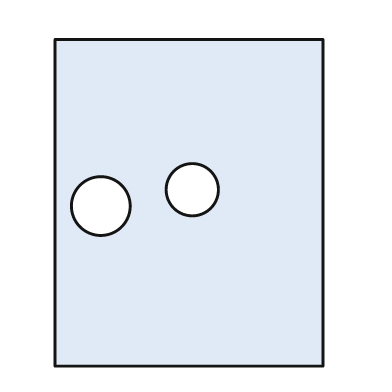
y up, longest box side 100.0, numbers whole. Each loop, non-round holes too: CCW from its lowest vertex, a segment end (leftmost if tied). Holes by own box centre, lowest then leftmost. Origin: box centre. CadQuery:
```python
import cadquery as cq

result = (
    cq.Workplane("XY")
    .moveTo(-41.0, -50.0)
    .lineTo(41.0, -50.0)
    .lineTo(41.0, 50.0)
    .lineTo(-41.0, 50.0)
    .close()
    .moveTo(-27.0, -1.0)
    .circle(9.0)
    .moveTo(1.0, 4.0)
    .circle(8.0)
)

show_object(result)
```